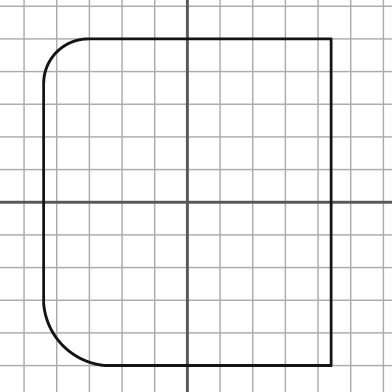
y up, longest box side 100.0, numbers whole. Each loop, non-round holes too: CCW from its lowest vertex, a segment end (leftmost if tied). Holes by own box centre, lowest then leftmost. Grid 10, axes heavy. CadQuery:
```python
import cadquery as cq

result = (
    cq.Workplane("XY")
    .moveTo(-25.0, -50.0)
    .lineTo(44.0, -50.0)
    .lineTo(44.0, 50.0)
    .lineTo(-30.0, 50.0)
    .threePointArc((-40.0, 46.0), (-44.0, 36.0))
    .lineTo(-44.0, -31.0)
    .threePointArc((-38.0, -44.0), (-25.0, -50.0))
    .close()
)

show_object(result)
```